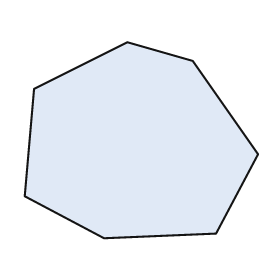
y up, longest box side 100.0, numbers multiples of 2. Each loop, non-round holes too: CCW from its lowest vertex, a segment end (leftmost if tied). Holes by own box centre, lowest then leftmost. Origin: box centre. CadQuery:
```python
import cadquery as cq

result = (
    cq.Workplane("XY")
    .moveTo(-16.0, -42.0)
    .lineTo(32.0, -40.0)
    .lineTo(50.0, -6.0)
    .lineTo(22.0, 34.0)
    .lineTo(-6.0, 42.0)
    .lineTo(-46.0, 22.0)
    .lineTo(-50.0, -24.0)
    .close()
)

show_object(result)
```